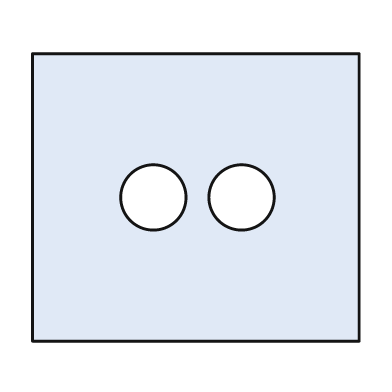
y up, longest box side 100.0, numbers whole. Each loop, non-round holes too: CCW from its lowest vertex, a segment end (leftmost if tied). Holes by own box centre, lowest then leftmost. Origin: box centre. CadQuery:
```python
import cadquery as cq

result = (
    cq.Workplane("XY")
    .moveTo(-50.0, -44.0)
    .lineTo(50.0, -44.0)
    .lineTo(50.0, 44.0)
    .lineTo(-50.0, 44.0)
    .close()
    .moveTo(-13.0, 0.0)
    .circle(10.0)
    .moveTo(14.0, 0.0)
    .circle(10.0)
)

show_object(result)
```